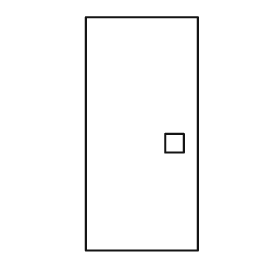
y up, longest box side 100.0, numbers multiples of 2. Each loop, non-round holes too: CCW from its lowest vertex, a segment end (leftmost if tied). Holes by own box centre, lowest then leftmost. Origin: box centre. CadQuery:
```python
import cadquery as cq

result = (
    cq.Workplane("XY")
    .moveTo(-24.0, -50.0)
    .lineTo(24.0, -50.0)
    .lineTo(24.0, 50.0)
    .lineTo(-24.0, 50.0)
    .close()
    .moveTo(10.0, -8.0)
    .lineTo(18.0, -8.0)
    .lineTo(18.0, 0.0)
    .lineTo(10.0, 0.0)
    .close()
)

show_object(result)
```